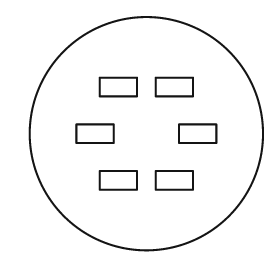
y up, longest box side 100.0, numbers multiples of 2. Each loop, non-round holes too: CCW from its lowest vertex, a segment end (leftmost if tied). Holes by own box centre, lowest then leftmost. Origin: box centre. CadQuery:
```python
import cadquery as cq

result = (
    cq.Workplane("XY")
    .moveTo(0.0, 0.0)
    .circle(50.0)
    .moveTo(-20.0, -24.0)
    .lineTo(-4.0, -24.0)
    .lineTo(-4.0, -16.0)
    .lineTo(-20.0, -16.0)
    .close()
    .moveTo(4.0, -24.0)
    .lineTo(20.0, -24.0)
    .lineTo(20.0, -16.0)
    .lineTo(4.0, -16.0)
    .close()
    .moveTo(-30.0, -4.0)
    .lineTo(-14.0, -4.0)
    .lineTo(-14.0, 4.0)
    .lineTo(-30.0, 4.0)
    .close()
    .moveTo(14.0, -4.0)
    .lineTo(30.0, -4.0)
    .lineTo(30.0, 4.0)
    .lineTo(14.0, 4.0)
    .close()
    .moveTo(-20.0, 16.0)
    .lineTo(-4.0, 16.0)
    .lineTo(-4.0, 24.0)
    .lineTo(-20.0, 24.0)
    .close()
    .moveTo(4.0, 16.0)
    .lineTo(20.0, 16.0)
    .lineTo(20.0, 24.0)
    .lineTo(4.0, 24.0)
    .close()
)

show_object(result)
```